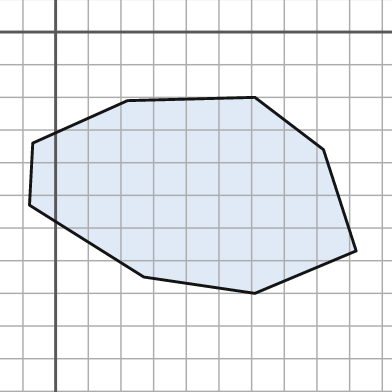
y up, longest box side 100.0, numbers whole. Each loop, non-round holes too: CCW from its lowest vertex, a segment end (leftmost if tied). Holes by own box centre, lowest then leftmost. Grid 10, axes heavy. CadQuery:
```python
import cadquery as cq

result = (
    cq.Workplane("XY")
    .moveTo(61.0, -80.0)
    .lineTo(92.0, -67.0)
    .lineTo(82.0, -36.0)
    .lineTo(61.0, -20.0)
    .lineTo(22.0, -21.0)
    .lineTo(-7.0, -34.0)
    .lineTo(-8.0, -53.0)
    .lineTo(27.0, -75.0)
    .close()
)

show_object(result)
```